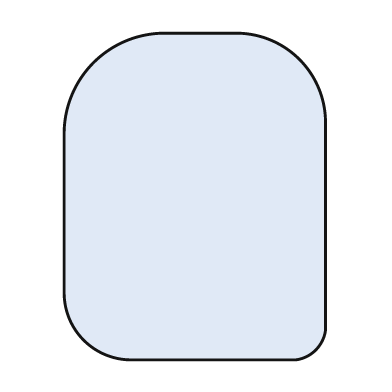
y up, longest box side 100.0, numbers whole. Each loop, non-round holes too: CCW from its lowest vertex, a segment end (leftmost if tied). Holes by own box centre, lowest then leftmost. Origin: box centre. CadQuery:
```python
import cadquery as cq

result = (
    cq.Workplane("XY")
    .moveTo(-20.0, -50.0)
    .lineTo(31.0, -50.0)
    .threePointArc((37.0, -47.0), (40.0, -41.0))
    .lineTo(40.0, 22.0)
    .threePointArc((32.0, 42.0), (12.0, 50.0))
    .lineTo(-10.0, 50.0)
    .threePointArc((-31.0, 41.0), (-40.0, 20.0))
    .lineTo(-40.0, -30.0)
    .threePointArc((-34.0, -44.0), (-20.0, -50.0))
    .close()
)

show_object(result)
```